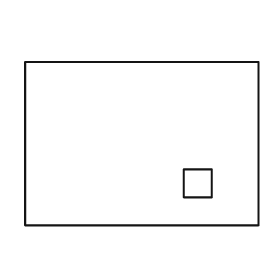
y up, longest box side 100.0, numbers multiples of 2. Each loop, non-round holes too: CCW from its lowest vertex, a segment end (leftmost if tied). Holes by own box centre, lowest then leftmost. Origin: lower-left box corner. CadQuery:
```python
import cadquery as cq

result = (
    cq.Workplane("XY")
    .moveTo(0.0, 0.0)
    .lineTo(100.0, 0.0)
    .lineTo(100.0, 70.0)
    .lineTo(0.0, 70.0)
    .close()
    .moveTo(68.0, 12.0)
    .lineTo(80.0, 12.0)
    .lineTo(80.0, 24.0)
    .lineTo(68.0, 24.0)
    .close()
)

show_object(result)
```